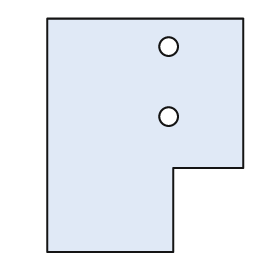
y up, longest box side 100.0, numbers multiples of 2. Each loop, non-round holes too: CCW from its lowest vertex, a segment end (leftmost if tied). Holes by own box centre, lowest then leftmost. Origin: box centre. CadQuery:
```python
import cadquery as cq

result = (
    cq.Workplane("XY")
    .moveTo(-42.0, -50.0)
    .lineTo(12.0, -50.0)
    .lineTo(12.0, -14.0)
    .lineTo(42.0, -14.0)
    .lineTo(42.0, 50.0)
    .lineTo(-42.0, 50.0)
    .close()
    .moveTo(10.0, 8.0)
    .circle(4.0)
    .moveTo(10.0, 38.0)
    .circle(4.0)
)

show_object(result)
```